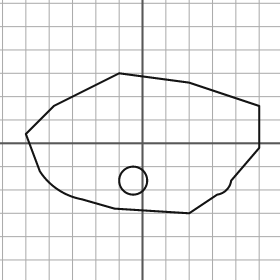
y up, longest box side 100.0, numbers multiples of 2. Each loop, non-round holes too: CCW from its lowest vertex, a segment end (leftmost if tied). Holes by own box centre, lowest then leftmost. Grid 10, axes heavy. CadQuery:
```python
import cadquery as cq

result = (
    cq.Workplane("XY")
    .moveTo(20.0, -30.0)
    .lineTo(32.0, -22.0)
    .threePointArc((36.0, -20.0), (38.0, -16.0))
    .lineTo(50.0, -2.0)
    .lineTo(50.0, 16.0)
    .lineTo(20.0, 26.0)
    .lineTo(-10.0, 30.0)
    .lineTo(-38.0, 16.0)
    .lineTo(-50.0, 4.0)
    .lineTo(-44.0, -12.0)
    .threePointArc((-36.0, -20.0), (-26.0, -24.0))
    .lineTo(-12.0, -28.0)
    .close()
    .moveTo(-4.0, -16.0)
    .circle(6.0)
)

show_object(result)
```